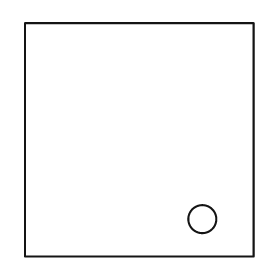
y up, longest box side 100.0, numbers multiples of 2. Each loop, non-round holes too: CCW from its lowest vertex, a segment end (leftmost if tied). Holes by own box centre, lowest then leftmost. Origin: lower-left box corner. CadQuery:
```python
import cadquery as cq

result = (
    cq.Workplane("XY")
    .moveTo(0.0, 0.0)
    .lineTo(98.0, 0.0)
    .lineTo(98.0, 100.0)
    .lineTo(0.0, 100.0)
    .close()
    .moveTo(76.0, 16.0)
    .circle(6.0)
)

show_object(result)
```